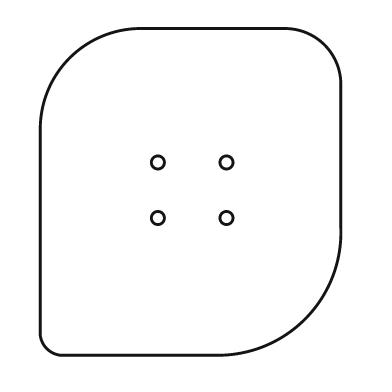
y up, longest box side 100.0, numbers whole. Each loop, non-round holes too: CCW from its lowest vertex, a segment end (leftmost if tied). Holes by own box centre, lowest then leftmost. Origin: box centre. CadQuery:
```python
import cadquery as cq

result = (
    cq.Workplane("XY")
    .moveTo(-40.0, -50.0)
    .lineTo(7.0, -50.0)
    .threePointArc((35.0, -39.0), (46.0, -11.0))
    .lineTo(46.0, 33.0)
    .threePointArc((41.0, 45.0), (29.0, 50.0))
    .lineTo(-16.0, 50.0)
    .threePointArc((-37.0, 41.0), (-46.0, 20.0))
    .lineTo(-46.0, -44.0)
    .threePointArc((-44.0, -48.0), (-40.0, -50.0))
    .close()
    .moveTo(-10.0, -8.0)
    .circle(2.0)
    .moveTo(11.0, -8.0)
    .circle(2.0)
    .moveTo(-10.0, 9.0)
    .circle(2.0)
    .moveTo(11.0, 9.0)
    .circle(2.0)
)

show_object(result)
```